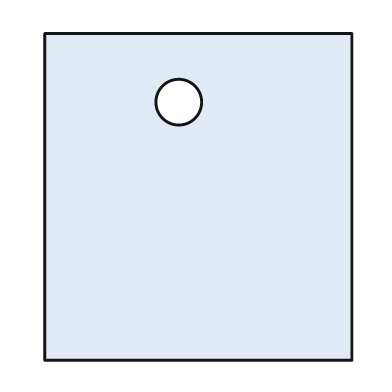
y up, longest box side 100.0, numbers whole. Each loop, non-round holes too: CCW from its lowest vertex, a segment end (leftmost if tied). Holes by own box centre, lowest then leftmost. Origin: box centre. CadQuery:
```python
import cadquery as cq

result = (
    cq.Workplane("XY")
    .moveTo(-47.0, -50.0)
    .lineTo(47.0, -50.0)
    .lineTo(47.0, 50.0)
    .lineTo(-47.0, 50.0)
    .close()
    .moveTo(-6.0, 29.0)
    .circle(7.0)
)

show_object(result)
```